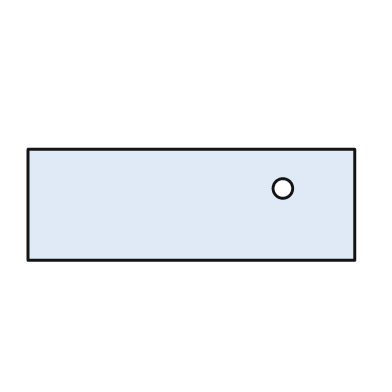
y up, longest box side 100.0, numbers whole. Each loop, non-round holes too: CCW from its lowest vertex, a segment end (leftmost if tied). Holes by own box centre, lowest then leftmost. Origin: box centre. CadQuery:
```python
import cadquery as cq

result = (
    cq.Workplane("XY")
    .moveTo(-50.0, -17.0)
    .lineTo(50.0, -17.0)
    .lineTo(50.0, 17.0)
    .lineTo(-50.0, 17.0)
    .close()
    .moveTo(28.0, 5.0)
    .circle(3.0)
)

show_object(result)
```